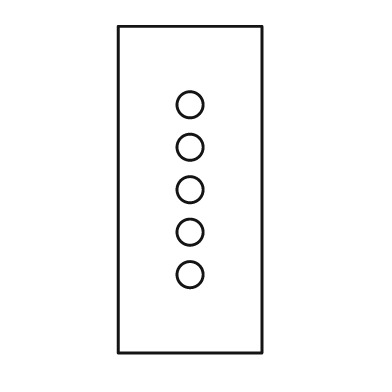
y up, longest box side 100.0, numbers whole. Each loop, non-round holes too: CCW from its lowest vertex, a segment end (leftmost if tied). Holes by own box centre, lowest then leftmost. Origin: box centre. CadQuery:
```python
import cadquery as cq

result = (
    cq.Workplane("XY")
    .moveTo(-22.0, -50.0)
    .lineTo(22.0, -50.0)
    .lineTo(22.0, 50.0)
    .lineTo(-22.0, 50.0)
    .close()
    .moveTo(0.0, -26.0)
    .circle(4.0)
    .moveTo(0.0, -13.0)
    .circle(4.0)
    .moveTo(0.0, 0.0)
    .circle(4.0)
    .moveTo(0.0, 13.0)
    .circle(4.0)
    .moveTo(0.0, 26.0)
    .circle(4.0)
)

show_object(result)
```